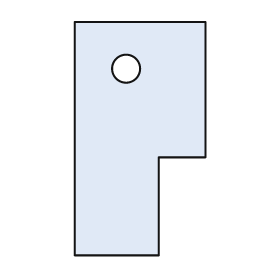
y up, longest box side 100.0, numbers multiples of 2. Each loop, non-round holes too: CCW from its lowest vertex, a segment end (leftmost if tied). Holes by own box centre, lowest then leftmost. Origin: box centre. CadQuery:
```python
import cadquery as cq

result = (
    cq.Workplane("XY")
    .moveTo(-28.0, -50.0)
    .lineTo(8.0, -50.0)
    .lineTo(8.0, -8.0)
    .lineTo(28.0, -8.0)
    .lineTo(28.0, 50.0)
    .lineTo(-28.0, 50.0)
    .close()
    .moveTo(-6.0, 30.0)
    .circle(6.0)
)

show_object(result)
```